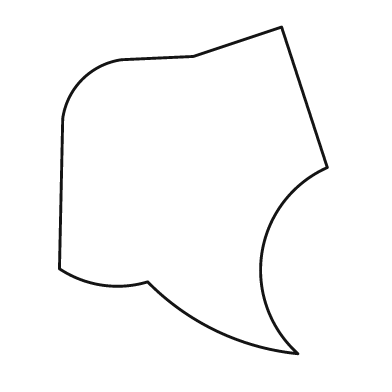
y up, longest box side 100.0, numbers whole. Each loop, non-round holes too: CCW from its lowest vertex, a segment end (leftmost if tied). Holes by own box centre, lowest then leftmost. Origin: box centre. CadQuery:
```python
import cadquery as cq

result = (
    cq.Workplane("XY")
    .moveTo(32.0, -50.0)
    .threePointArc((21.0, -19.0), (41.0, 7.0))
    .lineTo(27.0, 50.0)
    .lineTo(0.0, 41.0)
    .lineTo(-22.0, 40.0)
    .threePointArc((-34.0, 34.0), (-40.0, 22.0))
    .lineTo(-41.0, -24.0)
    .threePointArc((-28.0, -29.0), (-14.0, -28.0))
    .threePointArc((7.0, -43.0), (32.0, -50.0))
    .close()
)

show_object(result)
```